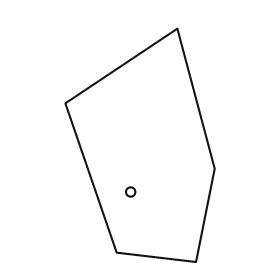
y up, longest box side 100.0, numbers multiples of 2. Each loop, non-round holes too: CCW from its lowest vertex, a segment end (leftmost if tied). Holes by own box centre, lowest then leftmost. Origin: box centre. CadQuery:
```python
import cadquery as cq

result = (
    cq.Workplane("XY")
    .moveTo(24.0, -50.0)
    .lineTo(32.0, -10.0)
    .lineTo(16.0, 50.0)
    .lineTo(-32.0, 18.0)
    .lineTo(-10.0, -46.0)
    .close()
    .moveTo(-4.0, -20.0)
    .circle(2.0)
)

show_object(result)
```